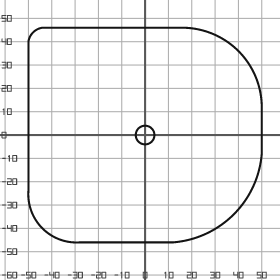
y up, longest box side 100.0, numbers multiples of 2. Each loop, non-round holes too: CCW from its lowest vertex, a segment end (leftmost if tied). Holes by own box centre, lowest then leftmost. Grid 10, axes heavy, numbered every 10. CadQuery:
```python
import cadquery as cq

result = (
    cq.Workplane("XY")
    .moveTo(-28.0, -46.0)
    .lineTo(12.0, -46.0)
    .threePointArc((38.0, -34.0), (50.0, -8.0))
    .lineTo(50.0, 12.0)
    .threePointArc((40.0, 36.0), (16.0, 46.0))
    .lineTo(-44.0, 46.0)
    .threePointArc((-48.0, 44.0), (-50.0, 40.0))
    .lineTo(-50.0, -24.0)
    .threePointArc((-44.0, -40.0), (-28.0, -46.0))
    .close()
    .moveTo(0.0, 0.0)
    .circle(4.0)
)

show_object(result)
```